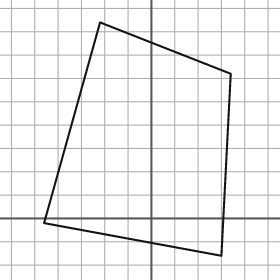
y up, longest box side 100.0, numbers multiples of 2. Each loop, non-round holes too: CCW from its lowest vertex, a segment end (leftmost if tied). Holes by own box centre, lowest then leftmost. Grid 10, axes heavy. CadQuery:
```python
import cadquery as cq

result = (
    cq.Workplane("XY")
    .moveTo(30.0, -16.0)
    .lineTo(34.0, 62.0)
    .lineTo(-22.0, 84.0)
    .lineTo(-46.0, -2.0)
    .close()
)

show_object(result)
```